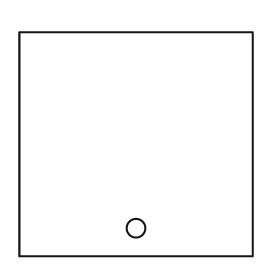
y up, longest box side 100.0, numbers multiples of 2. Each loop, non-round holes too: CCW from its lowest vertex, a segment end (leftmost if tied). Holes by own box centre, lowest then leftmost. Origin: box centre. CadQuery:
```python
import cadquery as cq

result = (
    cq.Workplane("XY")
    .moveTo(-50.0, -48.0)
    .lineTo(50.0, -48.0)
    .lineTo(50.0, 48.0)
    .lineTo(-50.0, 48.0)
    .close()
    .moveTo(0.0, -36.0)
    .circle(4.0)
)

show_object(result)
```